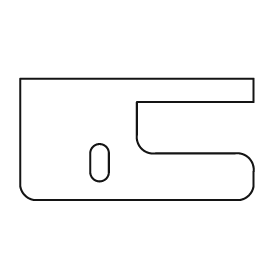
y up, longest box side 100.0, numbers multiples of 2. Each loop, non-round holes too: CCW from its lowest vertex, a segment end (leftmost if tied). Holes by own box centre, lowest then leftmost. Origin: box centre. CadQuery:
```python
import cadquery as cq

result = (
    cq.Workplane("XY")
    .moveTo(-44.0, -26.0)
    .lineTo(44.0, -26.0)
    .threePointArc((48.0, -24.0), (50.0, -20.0))
    .lineTo(50.0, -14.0)
    .threePointArc((48.0, -8.0), (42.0, -6.0))
    .lineTo(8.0, -6.0)
    .threePointArc((2.0, -4.0), (0.0, 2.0))
    .lineTo(0.0, 16.0)
    .lineTo(50.0, 16.0)
    .lineTo(50.0, 26.0)
    .lineTo(-50.0, 26.0)
    .lineTo(-50.0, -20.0)
    .threePointArc((-48.0, -24.0), (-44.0, -26.0))
    .close()
    .moveTo(-20.0, -14.0)
    .threePointArc((-16.0, -18.0), (-12.0, -14.0))
    .lineTo(-12.0, -6.0)
    .threePointArc((-16.0, -2.0), (-20.0, -6.0))
    .close()
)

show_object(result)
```